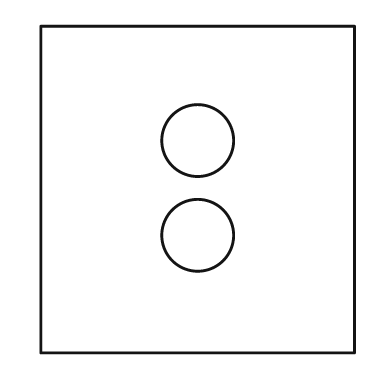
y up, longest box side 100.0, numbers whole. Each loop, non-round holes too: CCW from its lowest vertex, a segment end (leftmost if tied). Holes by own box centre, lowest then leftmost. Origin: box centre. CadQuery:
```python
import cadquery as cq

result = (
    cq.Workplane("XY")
    .moveTo(-48.0, -50.0)
    .lineTo(48.0, -50.0)
    .lineTo(48.0, 50.0)
    .lineTo(-48.0, 50.0)
    .close()
    .moveTo(0.0, -14.0)
    .circle(11.0)
    .moveTo(0.0, 15.0)
    .circle(11.0)
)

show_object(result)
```